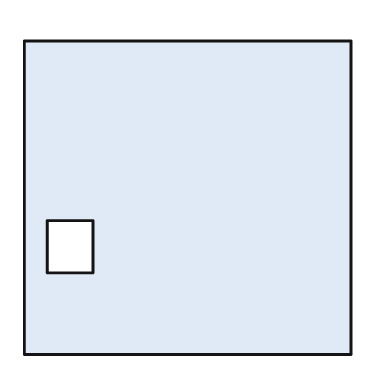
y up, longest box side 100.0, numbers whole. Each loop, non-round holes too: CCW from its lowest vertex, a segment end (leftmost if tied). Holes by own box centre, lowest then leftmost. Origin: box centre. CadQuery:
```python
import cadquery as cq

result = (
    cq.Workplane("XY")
    .moveTo(-50.0, -48.0)
    .lineTo(50.0, -48.0)
    .lineTo(50.0, 48.0)
    .lineTo(-50.0, 48.0)
    .close()
    .moveTo(-43.0, -23.0)
    .lineTo(-29.0, -23.0)
    .lineTo(-29.0, -7.0)
    .lineTo(-43.0, -7.0)
    .close()
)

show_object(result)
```